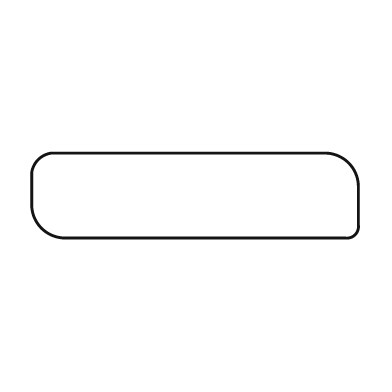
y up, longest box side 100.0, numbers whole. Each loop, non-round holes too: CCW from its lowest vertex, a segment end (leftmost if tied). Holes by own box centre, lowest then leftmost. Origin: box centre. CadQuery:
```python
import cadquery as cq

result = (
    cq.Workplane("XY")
    .moveTo(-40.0, -13.0)
    .lineTo(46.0, -13.0)
    .threePointArc((49.0, -12.0), (50.0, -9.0))
    .lineTo(50.0, 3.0)
    .threePointArc((47.0, 10.0), (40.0, 13.0))
    .lineTo(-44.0, 13.0)
    .threePointArc((-48.0, 11.0), (-50.0, 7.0))
    .lineTo(-50.0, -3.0)
    .threePointArc((-47.0, -10.0), (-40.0, -13.0))
    .close()
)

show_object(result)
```